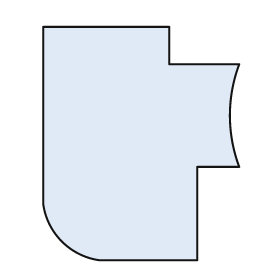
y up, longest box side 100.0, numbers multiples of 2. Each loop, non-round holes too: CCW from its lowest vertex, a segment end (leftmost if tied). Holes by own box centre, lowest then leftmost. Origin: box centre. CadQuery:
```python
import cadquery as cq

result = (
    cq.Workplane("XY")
    .moveTo(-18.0, -50.0)
    .lineTo(24.0, -50.0)
    .lineTo(24.0, -10.0)
    .lineTo(42.0, -10.0)
    .threePointArc((38.0, 12.0), (42.0, 34.0))
    .lineTo(12.0, 34.0)
    .lineTo(12.0, 50.0)
    .lineTo(-42.0, 50.0)
    .lineTo(-42.0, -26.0)
    .threePointArc((-34.0, -42.0), (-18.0, -50.0))
    .close()
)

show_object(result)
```